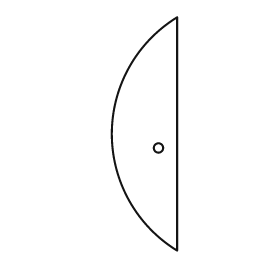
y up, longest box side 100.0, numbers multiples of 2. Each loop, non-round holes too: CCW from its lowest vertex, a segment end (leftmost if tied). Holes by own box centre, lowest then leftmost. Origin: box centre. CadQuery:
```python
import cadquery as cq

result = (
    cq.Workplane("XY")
    .moveTo(14.0, -50.0)
    .lineTo(14.0, 50.0)
    .threePointArc((-14.0, 0.0), (14.0, -50.0))
    .close()
    .moveTo(6.0, -6.0)
    .circle(2.0)
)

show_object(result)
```